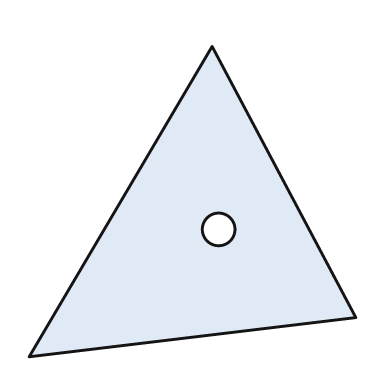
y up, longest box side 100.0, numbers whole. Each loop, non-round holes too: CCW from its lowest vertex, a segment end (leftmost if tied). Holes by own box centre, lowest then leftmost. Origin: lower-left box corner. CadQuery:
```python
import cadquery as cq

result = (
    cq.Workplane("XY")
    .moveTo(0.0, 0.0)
    .lineTo(100.0, 12.0)
    .lineTo(56.0, 95.0)
    .close()
    .moveTo(58.0, 39.0)
    .circle(5.0)
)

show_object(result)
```